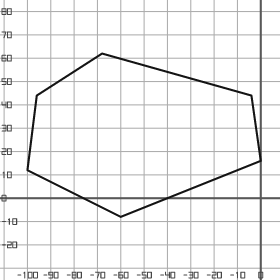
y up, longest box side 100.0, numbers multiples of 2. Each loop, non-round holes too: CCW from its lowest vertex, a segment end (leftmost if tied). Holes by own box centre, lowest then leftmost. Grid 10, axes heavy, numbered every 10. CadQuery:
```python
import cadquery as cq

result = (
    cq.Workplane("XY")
    .moveTo(-60.0, -8.0)
    .lineTo(0.0, 16.0)
    .lineTo(-4.0, 44.0)
    .lineTo(-68.0, 62.0)
    .lineTo(-96.0, 44.0)
    .lineTo(-100.0, 12.0)
    .close()
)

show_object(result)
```